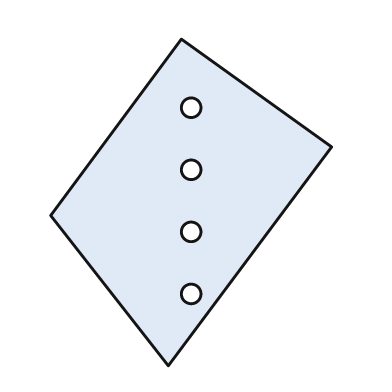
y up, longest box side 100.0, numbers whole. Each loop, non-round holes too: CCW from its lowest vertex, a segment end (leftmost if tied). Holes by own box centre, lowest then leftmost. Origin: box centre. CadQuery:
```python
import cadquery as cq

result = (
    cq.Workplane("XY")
    .moveTo(-7.0, -50.0)
    .lineTo(43.0, 17.0)
    .lineTo(-3.0, 50.0)
    .lineTo(-43.0, -4.0)
    .close()
    .moveTo(0.0, -28.0)
    .circle(3.0)
    .moveTo(0.0, -9.0)
    .circle(3.0)
    .moveTo(0.0, 10.0)
    .circle(3.0)
    .moveTo(0.0, 29.0)
    .circle(3.0)
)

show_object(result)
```